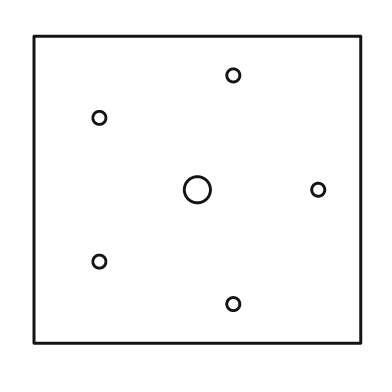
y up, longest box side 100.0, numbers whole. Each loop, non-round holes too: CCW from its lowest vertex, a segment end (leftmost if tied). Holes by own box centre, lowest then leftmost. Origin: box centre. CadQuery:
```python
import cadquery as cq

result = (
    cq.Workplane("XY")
    .moveTo(-50.0, -47.0)
    .lineTo(50.0, -47.0)
    .lineTo(50.0, 47.0)
    .lineTo(-50.0, 47.0)
    .close()
    .moveTo(11.0, -35.0)
    .circle(2.0)
    .moveTo(-30.0, -22.0)
    .circle(2.0)
    .moveTo(0.0, 0.0)
    .circle(4.0)
    .moveTo(37.0, 0.0)
    .circle(2.0)
    .moveTo(-30.0, 22.0)
    .circle(2.0)
    .moveTo(11.0, 35.0)
    .circle(2.0)
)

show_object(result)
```